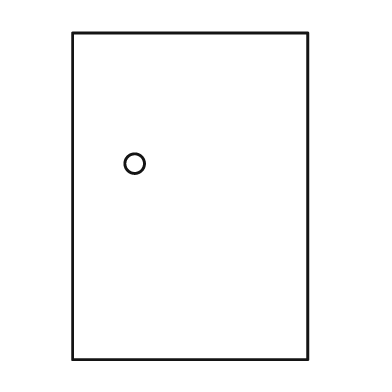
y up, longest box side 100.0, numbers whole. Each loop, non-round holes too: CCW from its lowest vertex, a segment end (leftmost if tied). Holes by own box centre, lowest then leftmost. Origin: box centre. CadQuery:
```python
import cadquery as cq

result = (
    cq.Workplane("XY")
    .moveTo(-36.0, -50.0)
    .lineTo(36.0, -50.0)
    .lineTo(36.0, 50.0)
    .lineTo(-36.0, 50.0)
    .close()
    .moveTo(-17.0, 10.0)
    .circle(3.0)
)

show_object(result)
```